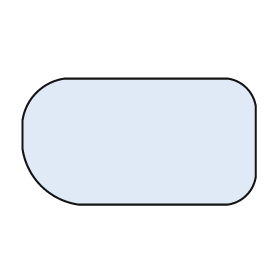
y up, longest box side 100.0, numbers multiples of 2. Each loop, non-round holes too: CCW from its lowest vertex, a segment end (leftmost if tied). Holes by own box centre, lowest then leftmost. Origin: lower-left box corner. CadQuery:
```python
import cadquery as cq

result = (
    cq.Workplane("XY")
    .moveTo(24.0, 0.0)
    .lineTo(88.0, 0.0)
    .threePointArc((96.0, 4.0), (100.0, 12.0))
    .lineTo(100.0, 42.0)
    .threePointArc((96.0, 50.0), (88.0, 54.0))
    .lineTo(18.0, 54.0)
    .threePointArc((6.0, 48.0), (0.0, 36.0))
    .lineTo(0.0, 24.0)
    .threePointArc((8.0, 8.0), (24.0, 0.0))
    .close()
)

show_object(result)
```